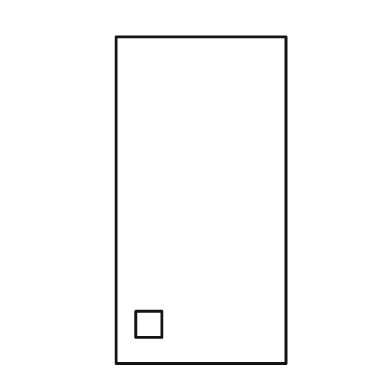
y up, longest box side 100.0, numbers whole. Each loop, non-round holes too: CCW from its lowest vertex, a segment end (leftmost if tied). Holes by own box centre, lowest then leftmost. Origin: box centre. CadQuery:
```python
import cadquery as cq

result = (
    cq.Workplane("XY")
    .moveTo(-26.0, -50.0)
    .lineTo(26.0, -50.0)
    .lineTo(26.0, 50.0)
    .lineTo(-26.0, 50.0)
    .close()
    .moveTo(-20.0, -42.0)
    .lineTo(-12.0, -42.0)
    .lineTo(-12.0, -34.0)
    .lineTo(-20.0, -34.0)
    .close()
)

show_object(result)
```